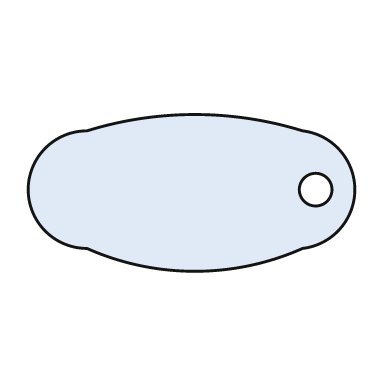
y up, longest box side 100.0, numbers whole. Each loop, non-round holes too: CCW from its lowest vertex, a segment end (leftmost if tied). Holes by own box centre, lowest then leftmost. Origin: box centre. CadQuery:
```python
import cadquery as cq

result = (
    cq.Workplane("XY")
    .moveTo(-32.0, -17.0)
    .threePointArc((1.0, -24.0), (34.0, -17.0))
    .threePointArc((50.0, 1.0), (34.0, 19.0))
    .threePointArc((1.0, 24.0), (-32.0, 19.0))
    .threePointArc((-50.0, 1.0), (-32.0, -17.0))
    .close()
    .moveTo(38.0, 1.0)
    .circle(5.0)
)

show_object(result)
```